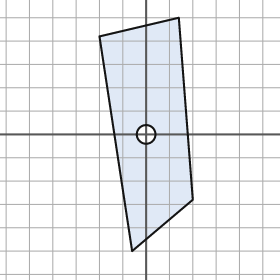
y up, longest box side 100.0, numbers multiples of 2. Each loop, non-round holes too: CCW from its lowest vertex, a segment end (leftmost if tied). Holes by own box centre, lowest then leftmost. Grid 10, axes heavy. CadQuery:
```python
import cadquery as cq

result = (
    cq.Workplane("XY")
    .moveTo(-6.0, -50.0)
    .lineTo(20.0, -28.0)
    .lineTo(14.0, 50.0)
    .lineTo(-20.0, 42.0)
    .close()
    .moveTo(0.0, 0.0)
    .circle(4.0)
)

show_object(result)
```